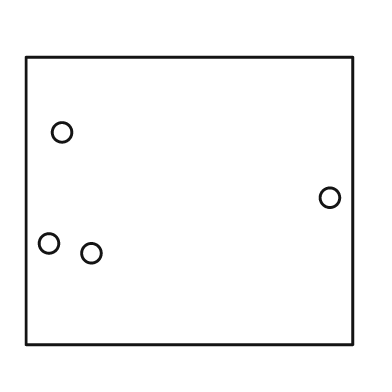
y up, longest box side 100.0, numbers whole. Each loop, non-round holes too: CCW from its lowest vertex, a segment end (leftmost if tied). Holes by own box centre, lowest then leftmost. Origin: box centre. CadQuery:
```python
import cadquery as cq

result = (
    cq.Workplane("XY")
    .moveTo(-50.0, -44.0)
    .lineTo(50.0, -44.0)
    .lineTo(50.0, 44.0)
    .lineTo(-50.0, 44.0)
    .close()
    .moveTo(-30.0, -16.0)
    .circle(3.0)
    .moveTo(-43.0, -13.0)
    .circle(3.0)
    .moveTo(43.0, 1.0)
    .circle(3.0)
    .moveTo(-39.0, 21.0)
    .circle(3.0)
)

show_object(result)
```